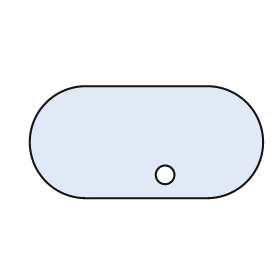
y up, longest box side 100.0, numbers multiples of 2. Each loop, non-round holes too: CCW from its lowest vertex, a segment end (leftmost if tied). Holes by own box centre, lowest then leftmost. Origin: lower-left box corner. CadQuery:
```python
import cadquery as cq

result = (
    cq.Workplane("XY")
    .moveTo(24.0, 0.0)
    .lineTo(76.0, 0.0)
    .threePointArc((100.0, 24.0), (76.0, 48.0))
    .lineTo(24.0, 48.0)
    .threePointArc((0.0, 24.0), (24.0, 0.0))
    .close()
    .moveTo(58.0, 10.0)
    .circle(4.0)
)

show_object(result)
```